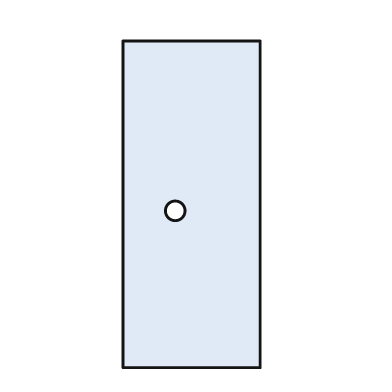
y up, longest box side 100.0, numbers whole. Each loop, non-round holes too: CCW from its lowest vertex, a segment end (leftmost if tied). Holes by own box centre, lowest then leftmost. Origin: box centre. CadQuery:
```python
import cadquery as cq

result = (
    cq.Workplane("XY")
    .moveTo(-21.0, -50.0)
    .lineTo(21.0, -50.0)
    .lineTo(21.0, 50.0)
    .lineTo(-21.0, 50.0)
    .close()
    .moveTo(-5.0, -2.0)
    .circle(3.0)
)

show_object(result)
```